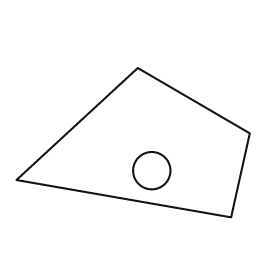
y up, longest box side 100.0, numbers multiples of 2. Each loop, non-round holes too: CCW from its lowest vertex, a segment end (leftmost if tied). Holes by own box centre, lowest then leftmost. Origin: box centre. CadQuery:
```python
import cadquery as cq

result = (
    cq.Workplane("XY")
    .moveTo(42.0, -32.0)
    .lineTo(50.0, 4.0)
    .lineTo(2.0, 32.0)
    .lineTo(-50.0, -16.0)
    .close()
    .moveTo(8.0, -12.0)
    .circle(8.0)
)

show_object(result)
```